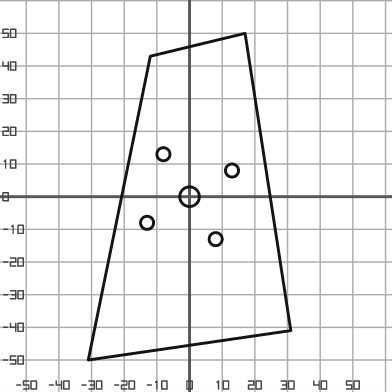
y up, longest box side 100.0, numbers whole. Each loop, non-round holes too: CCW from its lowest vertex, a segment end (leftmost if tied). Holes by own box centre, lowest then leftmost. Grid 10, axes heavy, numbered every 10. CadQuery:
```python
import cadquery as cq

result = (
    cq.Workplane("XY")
    .moveTo(-31.0, -50.0)
    .lineTo(31.0, -41.0)
    .lineTo(17.0, 50.0)
    .lineTo(-12.0, 43.0)
    .close()
    .moveTo(8.0, -13.0)
    .circle(2.0)
    .moveTo(-13.0, -8.0)
    .circle(2.0)
    .moveTo(0.0, 0.0)
    .circle(3.0)
    .moveTo(13.0, 8.0)
    .circle(2.0)
    .moveTo(-8.0, 13.0)
    .circle(2.0)
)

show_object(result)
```